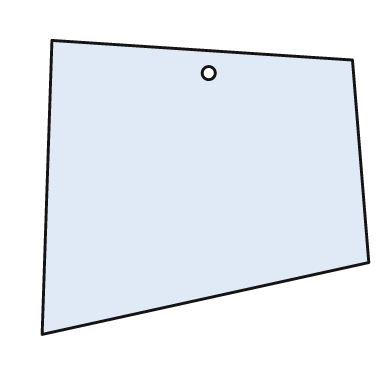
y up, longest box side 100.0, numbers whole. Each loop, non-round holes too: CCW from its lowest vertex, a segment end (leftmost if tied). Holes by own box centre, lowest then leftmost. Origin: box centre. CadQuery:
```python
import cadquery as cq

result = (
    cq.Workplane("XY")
    .moveTo(-50.0, -45.0)
    .lineTo(50.0, -23.0)
    .lineTo(45.0, 39.0)
    .lineTo(-47.0, 45.0)
    .close()
    .moveTo(1.0, 35.0)
    .circle(2.0)
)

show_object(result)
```